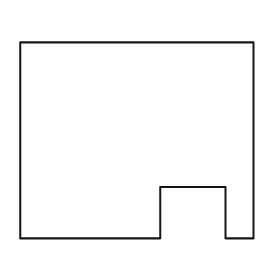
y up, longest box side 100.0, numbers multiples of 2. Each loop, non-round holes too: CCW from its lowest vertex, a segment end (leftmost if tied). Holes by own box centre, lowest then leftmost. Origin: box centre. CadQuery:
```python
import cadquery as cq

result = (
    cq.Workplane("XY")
    .moveTo(-50.0, -42.0)
    .lineTo(10.0, -42.0)
    .lineTo(10.0, -20.0)
    .lineTo(38.0, -20.0)
    .lineTo(38.0, -42.0)
    .lineTo(50.0, -42.0)
    .lineTo(50.0, 42.0)
    .lineTo(-50.0, 42.0)
    .close()
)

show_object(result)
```